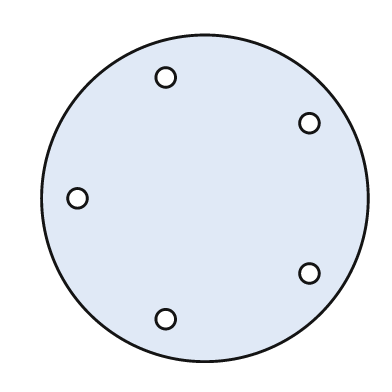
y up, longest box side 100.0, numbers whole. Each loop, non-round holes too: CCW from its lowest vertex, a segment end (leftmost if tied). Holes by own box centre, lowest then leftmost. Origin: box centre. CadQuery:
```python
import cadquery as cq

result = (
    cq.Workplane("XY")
    .moveTo(0.0, 0.0)
    .circle(50.0)
    .moveTo(-12.0, -37.0)
    .circle(3.0)
    .moveTo(32.0, -23.0)
    .circle(3.0)
    .moveTo(-39.0, 0.0)
    .circle(3.0)
    .moveTo(32.0, 23.0)
    .circle(3.0)
    .moveTo(-12.0, 37.0)
    .circle(3.0)
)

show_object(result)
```